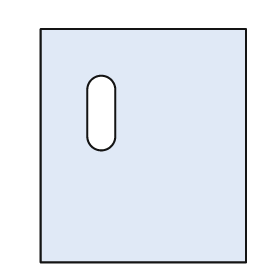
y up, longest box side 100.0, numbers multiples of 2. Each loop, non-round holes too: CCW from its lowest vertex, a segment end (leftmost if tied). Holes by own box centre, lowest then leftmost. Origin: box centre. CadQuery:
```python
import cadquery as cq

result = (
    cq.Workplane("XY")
    .moveTo(-44.0, -50.0)
    .lineTo(44.0, -50.0)
    .lineTo(44.0, 50.0)
    .lineTo(-44.0, 50.0)
    .close()
    .moveTo(-24.0, 4.0)
    .threePointArc((-18.0, -2.0), (-12.0, 4.0))
    .lineTo(-12.0, 24.0)
    .threePointArc((-18.0, 30.0), (-24.0, 24.0))
    .close()
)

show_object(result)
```